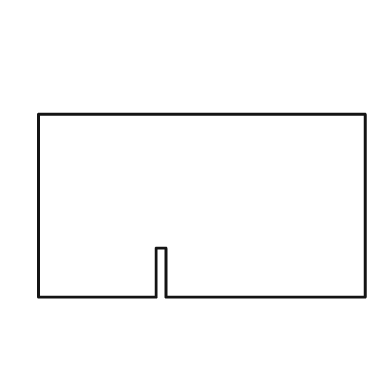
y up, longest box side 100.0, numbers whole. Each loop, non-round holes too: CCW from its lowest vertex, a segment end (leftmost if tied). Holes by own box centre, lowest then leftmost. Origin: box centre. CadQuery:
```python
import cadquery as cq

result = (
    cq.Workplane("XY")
    .moveTo(-50.0, -28.0)
    .lineTo(-14.0, -28.0)
    .lineTo(-14.0, -13.0)
    .lineTo(-11.0, -13.0)
    .lineTo(-11.0, -28.0)
    .lineTo(50.0, -28.0)
    .lineTo(50.0, 28.0)
    .lineTo(-50.0, 28.0)
    .close()
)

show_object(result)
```